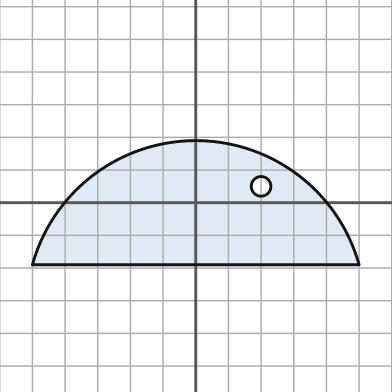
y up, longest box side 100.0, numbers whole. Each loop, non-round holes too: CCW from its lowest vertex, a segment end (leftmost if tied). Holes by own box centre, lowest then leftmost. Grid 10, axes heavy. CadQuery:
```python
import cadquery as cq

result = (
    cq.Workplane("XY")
    .moveTo(-50.0, -19.0)
    .lineTo(50.0, -19.0)
    .threePointArc((0.0, 19.0), (-50.0, -19.0))
    .close()
    .moveTo(20.0, 5.0)
    .circle(3.0)
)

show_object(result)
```